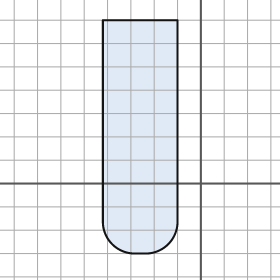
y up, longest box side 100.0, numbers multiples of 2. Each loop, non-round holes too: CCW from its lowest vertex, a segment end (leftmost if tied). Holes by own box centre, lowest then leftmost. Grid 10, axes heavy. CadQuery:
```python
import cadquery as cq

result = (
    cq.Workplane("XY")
    .moveTo(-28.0, -30.0)
    .lineTo(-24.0, -30.0)
    .threePointArc((-14.0, -26.0), (-10.0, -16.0))
    .lineTo(-10.0, 70.0)
    .lineTo(-42.0, 70.0)
    .lineTo(-42.0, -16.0)
    .threePointArc((-38.0, -26.0), (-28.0, -30.0))
    .close()
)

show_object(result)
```